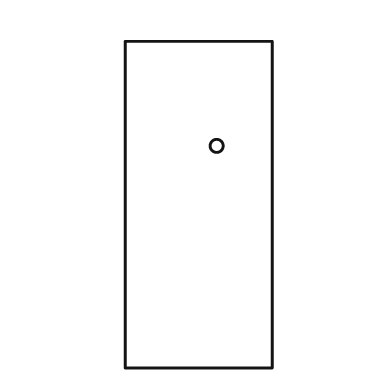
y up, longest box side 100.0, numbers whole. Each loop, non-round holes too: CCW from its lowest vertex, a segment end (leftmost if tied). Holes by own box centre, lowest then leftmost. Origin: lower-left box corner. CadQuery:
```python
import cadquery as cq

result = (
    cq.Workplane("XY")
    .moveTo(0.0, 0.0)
    .lineTo(45.0, 0.0)
    .lineTo(45.0, 100.0)
    .lineTo(0.0, 100.0)
    .close()
    .moveTo(28.0, 68.0)
    .circle(2.0)
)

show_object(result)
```